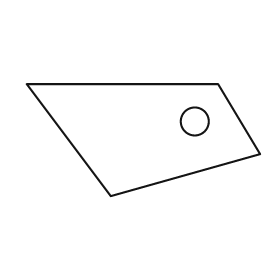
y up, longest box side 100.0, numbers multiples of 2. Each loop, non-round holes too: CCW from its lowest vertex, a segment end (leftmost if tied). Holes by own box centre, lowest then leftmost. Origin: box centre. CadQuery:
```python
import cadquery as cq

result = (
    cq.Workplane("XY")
    .moveTo(-14.0, -24.0)
    .lineTo(50.0, -6.0)
    .lineTo(32.0, 24.0)
    .lineTo(-50.0, 24.0)
    .close()
    .moveTo(22.0, 8.0)
    .circle(6.0)
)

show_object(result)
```